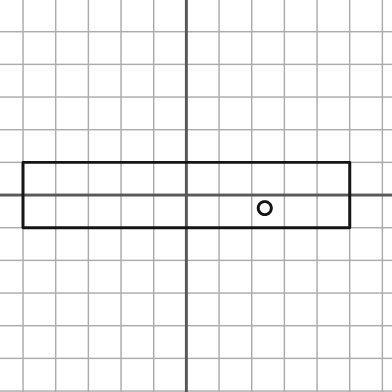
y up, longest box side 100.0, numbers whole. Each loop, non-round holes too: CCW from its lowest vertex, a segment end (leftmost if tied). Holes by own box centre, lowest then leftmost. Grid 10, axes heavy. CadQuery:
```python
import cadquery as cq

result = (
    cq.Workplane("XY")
    .moveTo(-50.0, -10.0)
    .lineTo(50.0, -10.0)
    .lineTo(50.0, 10.0)
    .lineTo(-50.0, 10.0)
    .close()
    .moveTo(24.0, -4.0)
    .circle(2.0)
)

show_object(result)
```